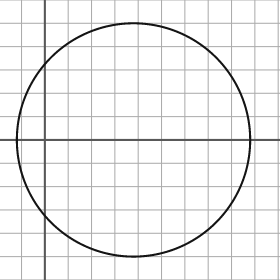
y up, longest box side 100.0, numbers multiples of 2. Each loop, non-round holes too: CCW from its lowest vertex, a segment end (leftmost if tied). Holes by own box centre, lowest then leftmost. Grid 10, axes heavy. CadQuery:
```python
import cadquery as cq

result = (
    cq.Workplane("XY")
    .moveTo(38.0, 0.0)
    .circle(50.0)
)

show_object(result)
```